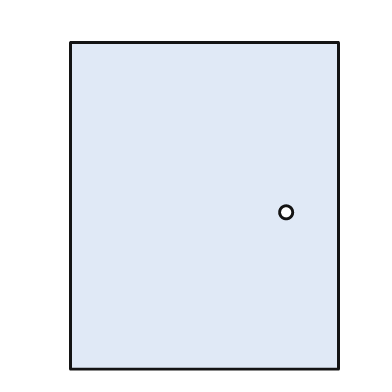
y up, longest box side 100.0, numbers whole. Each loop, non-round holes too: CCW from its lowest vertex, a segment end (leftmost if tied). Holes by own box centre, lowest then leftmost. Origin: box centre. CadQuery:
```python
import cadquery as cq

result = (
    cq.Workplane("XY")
    .moveTo(-41.0, -50.0)
    .lineTo(41.0, -50.0)
    .lineTo(41.0, 50.0)
    .lineTo(-41.0, 50.0)
    .close()
    .moveTo(25.0, -2.0)
    .circle(2.0)
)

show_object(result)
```